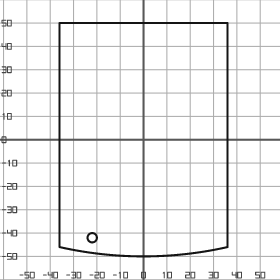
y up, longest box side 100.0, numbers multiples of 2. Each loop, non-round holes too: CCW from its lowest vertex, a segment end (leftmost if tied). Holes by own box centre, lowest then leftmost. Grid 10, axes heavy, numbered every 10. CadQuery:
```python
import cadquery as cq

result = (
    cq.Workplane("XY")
    .moveTo(-36.0, -46.0)
    .threePointArc((0.0, -50.0), (36.0, -46.0))
    .lineTo(36.0, 50.0)
    .lineTo(-36.0, 50.0)
    .close()
    .moveTo(-22.0, -42.0)
    .circle(2.0)
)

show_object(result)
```